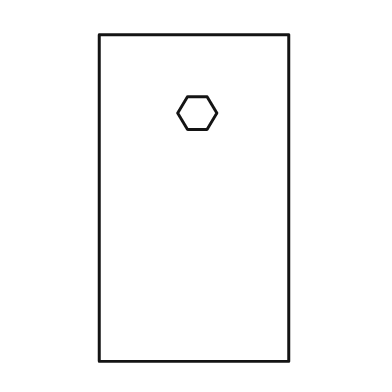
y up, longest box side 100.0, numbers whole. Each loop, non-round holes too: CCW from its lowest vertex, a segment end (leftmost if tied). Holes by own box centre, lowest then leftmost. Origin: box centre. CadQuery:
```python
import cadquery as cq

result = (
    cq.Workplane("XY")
    .moveTo(-29.0, -50.0)
    .lineTo(29.0, -50.0)
    .lineTo(29.0, 50.0)
    .lineTo(-29.0, 50.0)
    .close()
    .moveTo(-2.0, 21.0)
    .lineTo(4.0, 21.0)
    .lineTo(7.0, 26.0)
    .lineTo(4.0, 31.0)
    .lineTo(-2.0, 31.0)
    .lineTo(-5.0, 26.0)
    .close()
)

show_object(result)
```